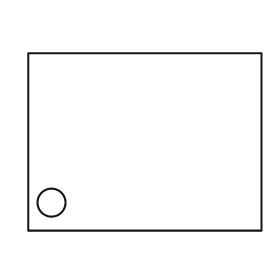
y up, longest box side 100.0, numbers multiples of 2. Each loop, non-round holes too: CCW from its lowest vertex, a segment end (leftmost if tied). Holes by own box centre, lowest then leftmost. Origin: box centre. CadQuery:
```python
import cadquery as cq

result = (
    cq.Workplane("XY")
    .moveTo(-50.0, -38.0)
    .lineTo(50.0, -38.0)
    .lineTo(50.0, 38.0)
    .lineTo(-50.0, 38.0)
    .close()
    .moveTo(-40.0, -26.0)
    .circle(6.0)
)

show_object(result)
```